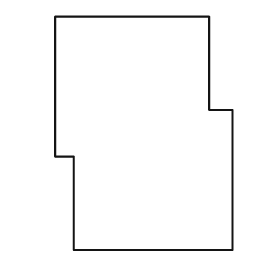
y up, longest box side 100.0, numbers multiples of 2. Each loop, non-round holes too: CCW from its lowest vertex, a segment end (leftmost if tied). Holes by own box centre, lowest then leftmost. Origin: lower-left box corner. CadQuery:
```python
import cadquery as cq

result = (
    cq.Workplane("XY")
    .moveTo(8.0, 0.0)
    .lineTo(76.0, 0.0)
    .lineTo(76.0, 60.0)
    .lineTo(66.0, 60.0)
    .lineTo(66.0, 100.0)
    .lineTo(0.0, 100.0)
    .lineTo(0.0, 40.0)
    .lineTo(8.0, 40.0)
    .close()
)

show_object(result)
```